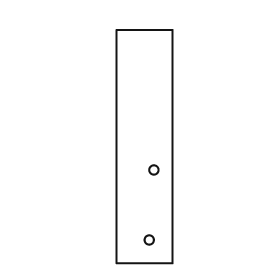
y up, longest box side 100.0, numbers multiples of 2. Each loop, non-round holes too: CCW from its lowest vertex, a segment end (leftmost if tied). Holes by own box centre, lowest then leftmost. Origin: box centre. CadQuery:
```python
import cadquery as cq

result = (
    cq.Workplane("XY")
    .moveTo(-12.0, -50.0)
    .lineTo(12.0, -50.0)
    .lineTo(12.0, 50.0)
    .lineTo(-12.0, 50.0)
    .close()
    .moveTo(2.0, -40.0)
    .circle(2.0)
    .moveTo(4.0, -10.0)
    .circle(2.0)
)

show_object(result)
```